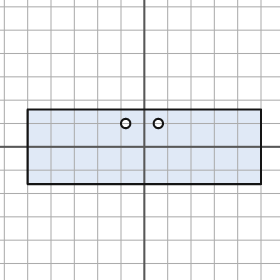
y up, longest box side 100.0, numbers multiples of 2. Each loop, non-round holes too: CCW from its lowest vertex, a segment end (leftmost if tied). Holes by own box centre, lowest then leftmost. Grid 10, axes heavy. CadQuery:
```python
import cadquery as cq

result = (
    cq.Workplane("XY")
    .moveTo(-50.0, -16.0)
    .lineTo(50.0, -16.0)
    .lineTo(50.0, 16.0)
    .lineTo(-50.0, 16.0)
    .close()
    .moveTo(-8.0, 10.0)
    .circle(2.0)
    .moveTo(6.0, 10.0)
    .circle(2.0)
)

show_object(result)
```